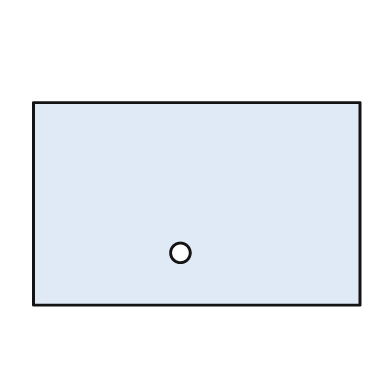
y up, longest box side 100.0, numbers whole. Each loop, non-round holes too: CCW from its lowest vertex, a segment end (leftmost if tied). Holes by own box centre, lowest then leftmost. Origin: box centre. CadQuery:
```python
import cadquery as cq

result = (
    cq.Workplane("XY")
    .moveTo(-50.0, -31.0)
    .lineTo(50.0, -31.0)
    .lineTo(50.0, 31.0)
    .lineTo(-50.0, 31.0)
    .close()
    .moveTo(-5.0, -15.0)
    .circle(3.0)
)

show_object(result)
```